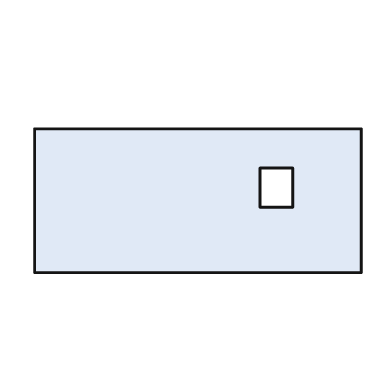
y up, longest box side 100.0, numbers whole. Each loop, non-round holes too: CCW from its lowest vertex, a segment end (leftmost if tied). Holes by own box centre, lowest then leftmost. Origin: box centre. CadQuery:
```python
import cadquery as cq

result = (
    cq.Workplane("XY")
    .moveTo(-50.0, -22.0)
    .lineTo(50.0, -22.0)
    .lineTo(50.0, 22.0)
    .lineTo(-50.0, 22.0)
    .close()
    .moveTo(19.0, -2.0)
    .lineTo(29.0, -2.0)
    .lineTo(29.0, 10.0)
    .lineTo(19.0, 10.0)
    .close()
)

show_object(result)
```